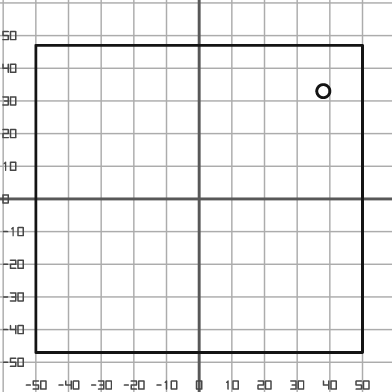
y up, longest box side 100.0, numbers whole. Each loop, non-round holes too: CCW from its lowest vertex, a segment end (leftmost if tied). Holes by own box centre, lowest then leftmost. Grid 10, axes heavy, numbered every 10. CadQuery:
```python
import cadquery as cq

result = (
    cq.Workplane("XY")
    .moveTo(-50.0, -47.0)
    .lineTo(50.0, -47.0)
    .lineTo(50.0, 47.0)
    .lineTo(-50.0, 47.0)
    .close()
    .moveTo(38.0, 33.0)
    .circle(2.0)
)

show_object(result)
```